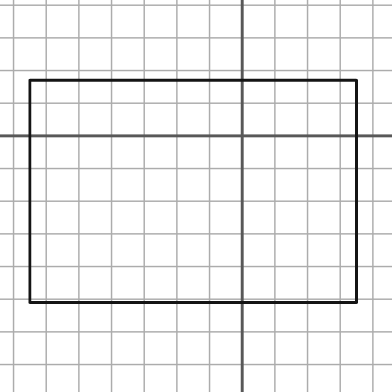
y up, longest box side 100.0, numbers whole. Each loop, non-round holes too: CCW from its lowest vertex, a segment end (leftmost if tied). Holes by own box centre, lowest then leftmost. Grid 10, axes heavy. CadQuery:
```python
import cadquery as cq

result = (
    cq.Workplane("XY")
    .moveTo(-65.0, -51.0)
    .lineTo(35.0, -51.0)
    .lineTo(35.0, 17.0)
    .lineTo(-65.0, 17.0)
    .close()
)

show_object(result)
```